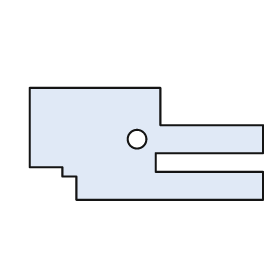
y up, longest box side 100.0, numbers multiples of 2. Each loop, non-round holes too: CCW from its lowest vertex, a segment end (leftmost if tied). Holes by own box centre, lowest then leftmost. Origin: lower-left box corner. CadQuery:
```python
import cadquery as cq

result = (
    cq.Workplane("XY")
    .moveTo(20.0, 0.0)
    .lineTo(100.0, 0.0)
    .lineTo(100.0, 12.0)
    .lineTo(54.0, 12.0)
    .lineTo(54.0, 20.0)
    .lineTo(100.0, 20.0)
    .lineTo(100.0, 32.0)
    .lineTo(56.0, 32.0)
    .lineTo(56.0, 48.0)
    .lineTo(0.0, 48.0)
    .lineTo(0.0, 14.0)
    .lineTo(14.0, 14.0)
    .lineTo(14.0, 10.0)
    .lineTo(20.0, 10.0)
    .close()
    .moveTo(46.0, 26.0)
    .circle(4.0)
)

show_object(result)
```